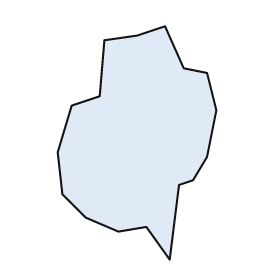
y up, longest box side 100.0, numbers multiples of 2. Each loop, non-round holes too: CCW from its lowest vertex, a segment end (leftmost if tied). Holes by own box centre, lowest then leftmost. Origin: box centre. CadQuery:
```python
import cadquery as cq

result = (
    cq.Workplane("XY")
    .moveTo(14.0, -50.0)
    .lineTo(18.0, -18.0)
    .lineTo(24.0, -16.0)
    .lineTo(30.0, -6.0)
    .lineTo(34.0, 14.0)
    .lineTo(30.0, 30.0)
    .lineTo(20.0, 32.0)
    .lineTo(12.0, 50.0)
    .lineTo(0.0, 46.0)
    .lineTo(-14.0, 44.0)
    .lineTo(-16.0, 20.0)
    .lineTo(-28.0, 16.0)
    .lineTo(-34.0, -4.0)
    .lineTo(-32.0, -22.0)
    .lineTo(-22.0, -32.0)
    .lineTo(-8.0, -38.0)
    .lineTo(4.0, -36.0)
    .close()
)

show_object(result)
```